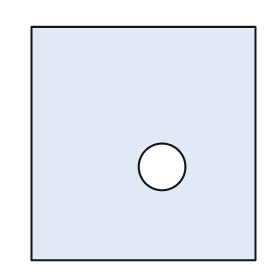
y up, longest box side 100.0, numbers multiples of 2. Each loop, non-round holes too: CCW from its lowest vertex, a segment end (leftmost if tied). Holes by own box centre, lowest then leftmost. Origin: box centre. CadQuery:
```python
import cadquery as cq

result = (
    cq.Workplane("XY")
    .moveTo(-48.0, -50.0)
    .lineTo(48.0, -50.0)
    .lineTo(48.0, 50.0)
    .lineTo(-48.0, 50.0)
    .close()
    .moveTo(8.0, -10.0)
    .circle(10.0)
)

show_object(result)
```